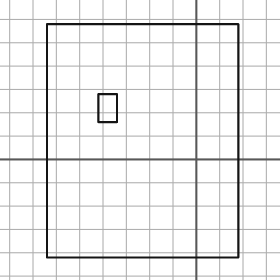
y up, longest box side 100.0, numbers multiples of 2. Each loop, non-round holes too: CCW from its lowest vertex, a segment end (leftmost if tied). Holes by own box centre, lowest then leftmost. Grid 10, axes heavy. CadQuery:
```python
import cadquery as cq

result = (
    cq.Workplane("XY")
    .moveTo(-64.0, -42.0)
    .lineTo(18.0, -42.0)
    .lineTo(18.0, 58.0)
    .lineTo(-64.0, 58.0)
    .close()
    .moveTo(-42.0, 16.0)
    .lineTo(-34.0, 16.0)
    .lineTo(-34.0, 28.0)
    .lineTo(-42.0, 28.0)
    .close()
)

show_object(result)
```